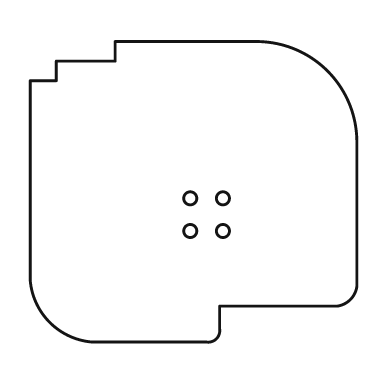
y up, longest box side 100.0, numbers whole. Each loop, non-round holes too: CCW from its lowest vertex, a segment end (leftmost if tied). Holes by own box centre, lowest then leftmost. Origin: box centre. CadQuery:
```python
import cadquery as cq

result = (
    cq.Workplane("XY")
    .moveTo(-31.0, -46.0)
    .lineTo(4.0, -46.0)
    .threePointArc((7.0, -45.0), (8.0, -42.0))
    .lineTo(8.0, -35.0)
    .lineTo(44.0, -35.0)
    .threePointArc((48.0, -33.0), (50.0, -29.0))
    .lineTo(50.0, 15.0)
    .threePointArc((41.0, 37.0), (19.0, 46.0))
    .lineTo(-24.0, 46.0)
    .lineTo(-24.0, 40.0)
    .lineTo(-42.0, 40.0)
    .lineTo(-42.0, 34.0)
    .lineTo(-50.0, 34.0)
    .lineTo(-50.0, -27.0)
    .threePointArc((-44.0, -40.0), (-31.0, -46.0))
    .close()
    .moveTo(-1.0, -12.0)
    .circle(2.0)
    .moveTo(9.0, -12.0)
    .circle(2.0)
    .moveTo(-1.0, -2.0)
    .circle(2.0)
    .moveTo(9.0, -2.0)
    .circle(2.0)
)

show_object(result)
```